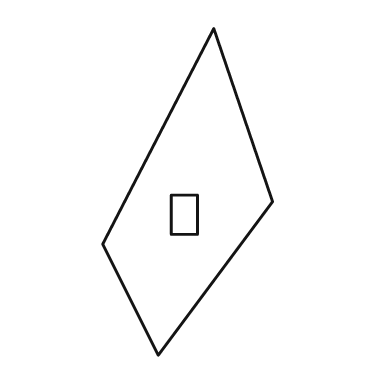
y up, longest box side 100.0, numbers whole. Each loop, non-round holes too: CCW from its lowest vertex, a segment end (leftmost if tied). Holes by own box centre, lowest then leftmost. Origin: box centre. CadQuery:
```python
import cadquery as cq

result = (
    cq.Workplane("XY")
    .moveTo(-9.0, -50.0)
    .lineTo(26.0, -3.0)
    .lineTo(8.0, 50.0)
    .lineTo(-26.0, -16.0)
    .close()
    .moveTo(-5.0, -13.0)
    .lineTo(3.0, -13.0)
    .lineTo(3.0, -1.0)
    .lineTo(-5.0, -1.0)
    .close()
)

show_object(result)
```